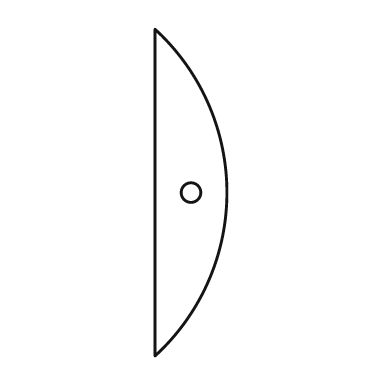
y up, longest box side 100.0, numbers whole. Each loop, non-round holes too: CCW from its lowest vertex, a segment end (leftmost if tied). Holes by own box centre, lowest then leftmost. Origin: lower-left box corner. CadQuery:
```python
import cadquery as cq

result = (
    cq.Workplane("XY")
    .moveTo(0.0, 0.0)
    .threePointArc((22.0, 50.0), (0.0, 100.0))
    .close()
    .moveTo(11.0, 50.0)
    .circle(3.0)
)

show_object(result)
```